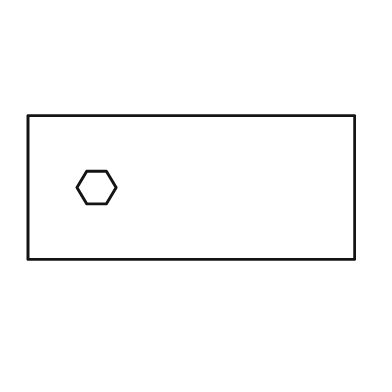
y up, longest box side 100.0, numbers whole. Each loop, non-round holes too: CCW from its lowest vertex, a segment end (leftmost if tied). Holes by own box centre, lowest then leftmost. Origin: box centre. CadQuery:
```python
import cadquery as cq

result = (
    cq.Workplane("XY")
    .moveTo(-50.0, -22.0)
    .lineTo(50.0, -22.0)
    .lineTo(50.0, 22.0)
    .lineTo(-50.0, 22.0)
    .close()
    .moveTo(-32.0, -5.0)
    .lineTo(-26.0, -5.0)
    .lineTo(-23.0, 0.0)
    .lineTo(-26.0, 5.0)
    .lineTo(-32.0, 5.0)
    .lineTo(-35.0, 0.0)
    .close()
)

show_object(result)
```